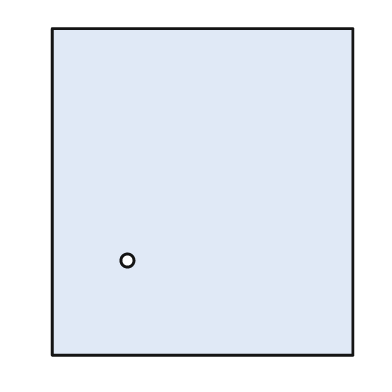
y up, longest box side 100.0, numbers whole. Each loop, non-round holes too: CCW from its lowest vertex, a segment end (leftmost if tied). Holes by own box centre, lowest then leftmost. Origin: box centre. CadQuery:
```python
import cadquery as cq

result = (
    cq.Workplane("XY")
    .moveTo(-46.0, -50.0)
    .lineTo(46.0, -50.0)
    .lineTo(46.0, 50.0)
    .lineTo(-46.0, 50.0)
    .close()
    .moveTo(-23.0, -21.0)
    .circle(2.0)
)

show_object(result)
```